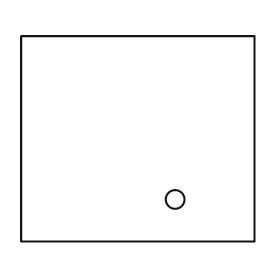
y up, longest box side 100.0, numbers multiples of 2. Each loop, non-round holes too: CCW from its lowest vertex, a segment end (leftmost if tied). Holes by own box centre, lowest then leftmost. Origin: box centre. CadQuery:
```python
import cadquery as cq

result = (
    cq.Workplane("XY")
    .moveTo(-50.0, -44.0)
    .lineTo(50.0, -44.0)
    .lineTo(50.0, 44.0)
    .lineTo(-50.0, 44.0)
    .close()
    .moveTo(16.0, -26.0)
    .circle(4.0)
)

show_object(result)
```